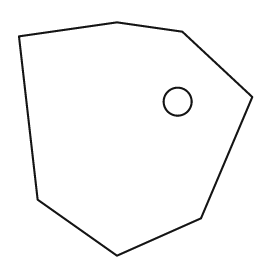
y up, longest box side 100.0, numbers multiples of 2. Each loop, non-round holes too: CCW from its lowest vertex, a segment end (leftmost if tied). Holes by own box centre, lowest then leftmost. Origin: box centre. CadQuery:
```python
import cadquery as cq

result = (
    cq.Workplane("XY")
    .moveTo(-8.0, -50.0)
    .lineTo(28.0, -34.0)
    .lineTo(50.0, 18.0)
    .lineTo(20.0, 46.0)
    .lineTo(-8.0, 50.0)
    .lineTo(-50.0, 44.0)
    .lineTo(-42.0, -26.0)
    .close()
    .moveTo(18.0, 16.0)
    .circle(6.0)
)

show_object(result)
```